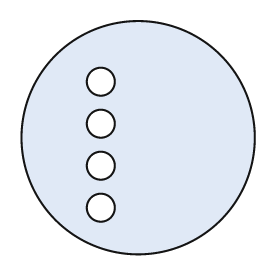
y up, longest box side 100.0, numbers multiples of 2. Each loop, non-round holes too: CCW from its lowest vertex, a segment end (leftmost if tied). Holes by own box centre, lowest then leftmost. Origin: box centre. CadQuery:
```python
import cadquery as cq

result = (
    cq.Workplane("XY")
    .moveTo(0.0, 0.0)
    .circle(50.0)
    .moveTo(-16.0, -30.0)
    .circle(6.0)
    .moveTo(-16.0, -12.0)
    .circle(6.0)
    .moveTo(-16.0, 6.0)
    .circle(6.0)
    .moveTo(-16.0, 24.0)
    .circle(6.0)
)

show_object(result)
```